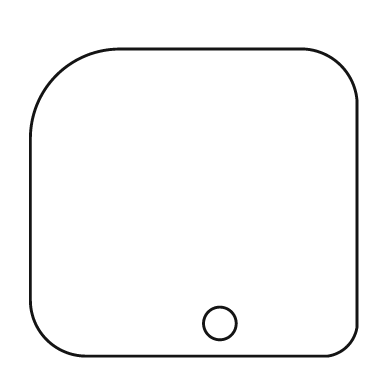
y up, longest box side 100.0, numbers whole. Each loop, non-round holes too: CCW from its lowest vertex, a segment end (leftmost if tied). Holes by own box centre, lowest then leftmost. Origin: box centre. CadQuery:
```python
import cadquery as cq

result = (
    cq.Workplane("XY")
    .moveTo(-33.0, -47.0)
    .lineTo(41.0, -47.0)
    .threePointArc((47.0, -44.0), (50.0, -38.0))
    .lineTo(50.0, 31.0)
    .threePointArc((45.0, 42.0), (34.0, 47.0))
    .lineTo(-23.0, 47.0)
    .threePointArc((-42.0, 39.0), (-50.0, 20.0))
    .lineTo(-50.0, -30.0)
    .threePointArc((-45.0, -42.0), (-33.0, -47.0))
    .close()
    .moveTo(8.0, -37.0)
    .circle(5.0)
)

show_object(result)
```